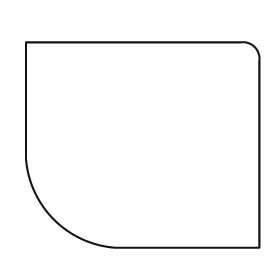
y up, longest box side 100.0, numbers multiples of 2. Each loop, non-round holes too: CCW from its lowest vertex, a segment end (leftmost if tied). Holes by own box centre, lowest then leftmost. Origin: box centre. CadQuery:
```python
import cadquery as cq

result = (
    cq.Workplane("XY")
    .moveTo(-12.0, -44.0)
    .lineTo(50.0, -44.0)
    .lineTo(50.0, 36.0)
    .threePointArc((48.0, 42.0), (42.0, 44.0))
    .lineTo(-50.0, 44.0)
    .lineTo(-50.0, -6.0)
    .threePointArc((-38.0, -32.0), (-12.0, -44.0))
    .close()
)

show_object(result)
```